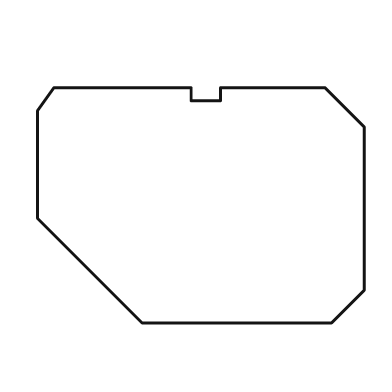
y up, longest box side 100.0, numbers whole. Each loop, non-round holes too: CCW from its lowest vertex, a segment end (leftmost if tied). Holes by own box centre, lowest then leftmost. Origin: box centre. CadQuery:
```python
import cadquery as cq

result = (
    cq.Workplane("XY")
    .moveTo(-18.0, -36.0)
    .lineTo(40.0, -36.0)
    .lineTo(50.0, -26.0)
    .lineTo(50.0, 24.0)
    .lineTo(38.0, 36.0)
    .lineTo(6.0, 36.0)
    .lineTo(6.0, 32.0)
    .lineTo(-3.0, 32.0)
    .lineTo(-3.0, 36.0)
    .lineTo(-45.0, 36.0)
    .lineTo(-50.0, 29.0)
    .lineTo(-50.0, -4.0)
    .close()
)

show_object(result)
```